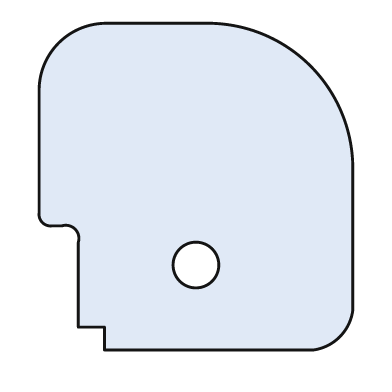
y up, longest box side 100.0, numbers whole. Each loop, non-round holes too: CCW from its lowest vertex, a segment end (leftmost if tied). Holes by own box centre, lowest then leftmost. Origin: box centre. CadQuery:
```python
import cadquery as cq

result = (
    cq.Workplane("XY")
    .moveTo(-28.0, -50.0)
    .lineTo(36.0, -50.0)
    .threePointArc((44.0, -46.0), (48.0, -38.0))
    .lineTo(48.0, 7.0)
    .threePointArc((35.0, 37.0), (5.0, 50.0))
    .lineTo(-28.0, 50.0)
    .threePointArc((-42.0, 44.0), (-48.0, 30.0))
    .lineTo(-48.0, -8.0)
    .threePointArc((-47.0, -11.0), (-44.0, -12.0))
    .lineTo(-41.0, -12.0)
    .threePointArc((-37.0, -13.0), (-36.0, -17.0))
    .lineTo(-36.0, -43.0)
    .lineTo(-28.0, -43.0)
    .close()
    .moveTo(0.0, -24.0)
    .circle(7.0)
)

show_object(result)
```